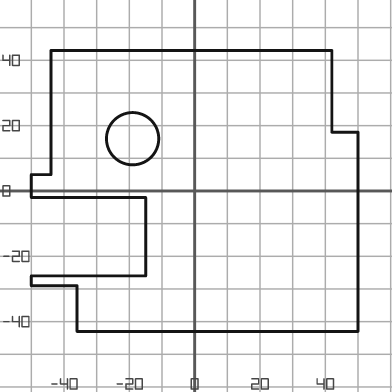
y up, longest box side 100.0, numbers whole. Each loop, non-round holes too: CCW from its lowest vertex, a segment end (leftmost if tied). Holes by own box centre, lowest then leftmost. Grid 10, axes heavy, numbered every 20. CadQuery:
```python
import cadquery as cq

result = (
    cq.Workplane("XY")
    .moveTo(-36.0, -43.0)
    .lineTo(50.0, -43.0)
    .lineTo(50.0, 18.0)
    .lineTo(42.0, 18.0)
    .lineTo(42.0, 43.0)
    .lineTo(-44.0, 43.0)
    .lineTo(-44.0, 5.0)
    .lineTo(-50.0, 5.0)
    .lineTo(-50.0, -2.0)
    .lineTo(-15.0, -2.0)
    .lineTo(-15.0, -26.0)
    .lineTo(-50.0, -26.0)
    .lineTo(-50.0, -29.0)
    .lineTo(-36.0, -29.0)
    .close()
    .moveTo(-19.0, 16.0)
    .circle(8.0)
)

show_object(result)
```